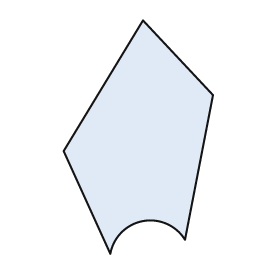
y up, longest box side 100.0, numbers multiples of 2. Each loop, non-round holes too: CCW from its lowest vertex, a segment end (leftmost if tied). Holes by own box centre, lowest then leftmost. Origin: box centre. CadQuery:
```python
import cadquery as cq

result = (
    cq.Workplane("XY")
    .moveTo(-12.0, -50.0)
    .threePointArc((2.0, -36.0), (20.0, -44.0))
    .lineTo(32.0, 18.0)
    .lineTo(2.0, 50.0)
    .lineTo(-32.0, -6.0)
    .close()
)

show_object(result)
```